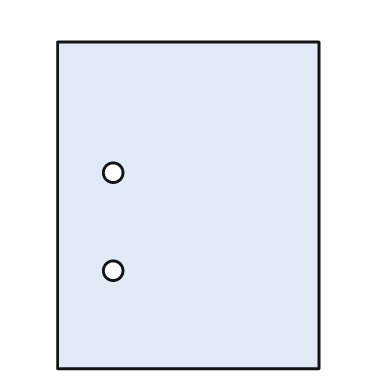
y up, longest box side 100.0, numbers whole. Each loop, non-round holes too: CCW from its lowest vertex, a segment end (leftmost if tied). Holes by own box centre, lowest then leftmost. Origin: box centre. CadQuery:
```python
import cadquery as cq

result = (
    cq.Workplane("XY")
    .moveTo(-40.0, -50.0)
    .lineTo(40.0, -50.0)
    .lineTo(40.0, 50.0)
    .lineTo(-40.0, 50.0)
    .close()
    .moveTo(-23.0, -20.0)
    .circle(3.0)
    .moveTo(-23.0, 10.0)
    .circle(3.0)
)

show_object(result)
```